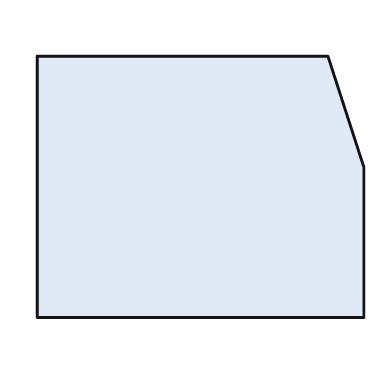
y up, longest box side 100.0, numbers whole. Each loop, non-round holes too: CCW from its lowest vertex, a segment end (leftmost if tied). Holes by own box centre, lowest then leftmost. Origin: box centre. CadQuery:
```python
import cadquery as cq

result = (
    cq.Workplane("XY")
    .moveTo(-50.0, -40.0)
    .lineTo(50.0, -40.0)
    .lineTo(50.0, 6.0)
    .lineTo(39.0, 40.0)
    .lineTo(-50.0, 40.0)
    .close()
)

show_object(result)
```